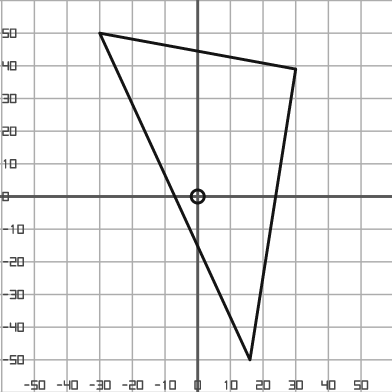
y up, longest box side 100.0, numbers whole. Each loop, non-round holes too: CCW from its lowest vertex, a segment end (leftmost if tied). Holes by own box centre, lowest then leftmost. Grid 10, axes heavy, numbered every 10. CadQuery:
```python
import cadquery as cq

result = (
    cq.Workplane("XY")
    .moveTo(16.0, -50.0)
    .lineTo(30.0, 39.0)
    .lineTo(-30.0, 50.0)
    .close()
    .moveTo(0.0, 0.0)
    .circle(2.0)
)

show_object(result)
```